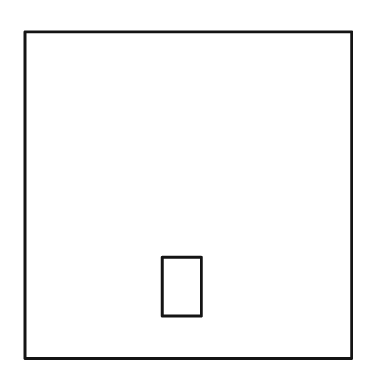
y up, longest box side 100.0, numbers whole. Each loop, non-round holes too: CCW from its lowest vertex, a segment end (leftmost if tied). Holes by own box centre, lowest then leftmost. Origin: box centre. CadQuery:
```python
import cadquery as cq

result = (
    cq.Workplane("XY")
    .moveTo(-50.0, -50.0)
    .lineTo(50.0, -50.0)
    .lineTo(50.0, 50.0)
    .lineTo(-50.0, 50.0)
    .close()
    .moveTo(-8.0, -37.0)
    .lineTo(4.0, -37.0)
    .lineTo(4.0, -19.0)
    .lineTo(-8.0, -19.0)
    .close()
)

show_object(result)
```